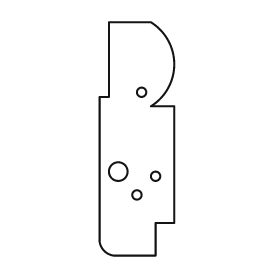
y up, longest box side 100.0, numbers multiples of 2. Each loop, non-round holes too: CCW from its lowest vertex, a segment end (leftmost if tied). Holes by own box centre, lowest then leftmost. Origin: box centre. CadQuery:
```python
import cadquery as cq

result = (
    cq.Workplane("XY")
    .moveTo(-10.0, -50.0)
    .lineTo(8.0, -50.0)
    .lineTo(8.0, -36.0)
    .lineTo(16.0, -36.0)
    .lineTo(16.0, 14.0)
    .lineTo(6.0, 14.0)
    .threePointArc((16.0, 32.0), (6.0, 50.0))
    .lineTo(-12.0, 50.0)
    .lineTo(-12.0, 18.0)
    .lineTo(-16.0, 18.0)
    .lineTo(-16.0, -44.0)
    .threePointArc((-14.0, -48.0), (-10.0, -50.0))
    .close()
    .moveTo(0.0, -24.0)
    .circle(2.0)
    .moveTo(8.0, -16.0)
    .circle(2.0)
    .moveTo(-8.0, -14.0)
    .circle(4.0)
    .moveTo(2.0, 20.0)
    .circle(2.0)
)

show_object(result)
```